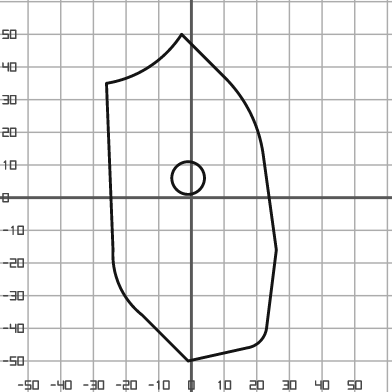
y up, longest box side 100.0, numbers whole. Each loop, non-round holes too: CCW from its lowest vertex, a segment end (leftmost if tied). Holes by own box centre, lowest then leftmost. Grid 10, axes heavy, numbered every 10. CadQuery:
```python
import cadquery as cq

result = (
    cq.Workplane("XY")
    .moveTo(-1.0, -50.0)
    .lineTo(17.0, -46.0)
    .threePointArc((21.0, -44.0), (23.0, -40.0))
    .lineTo(26.0, -16.0)
    .lineTo(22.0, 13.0)
    .threePointArc((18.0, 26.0), (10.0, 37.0))
    .lineTo(-3.0, 50.0)
    .threePointArc((-13.0, 40.0), (-26.0, 35.0))
    .lineTo(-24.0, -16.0)
    .threePointArc((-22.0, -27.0), (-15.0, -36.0))
    .close()
    .moveTo(-1.0, 6.0)
    .circle(5.0)
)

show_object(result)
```